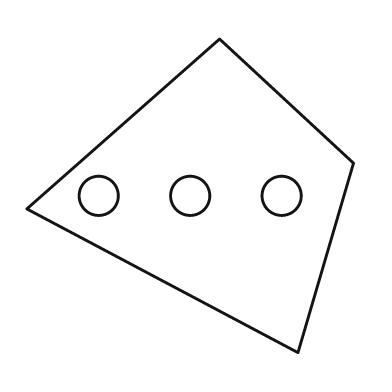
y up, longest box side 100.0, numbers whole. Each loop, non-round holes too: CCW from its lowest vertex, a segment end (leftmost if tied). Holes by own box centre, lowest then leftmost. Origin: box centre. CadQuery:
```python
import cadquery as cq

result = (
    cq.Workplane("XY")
    .moveTo(33.0, -48.0)
    .lineTo(50.0, 10.0)
    .lineTo(9.0, 48.0)
    .lineTo(-50.0, -4.0)
    .close()
    .moveTo(-28.0, 0.0)
    .circle(6.0)
    .moveTo(0.0, 0.0)
    .circle(6.0)
    .moveTo(28.0, 0.0)
    .circle(6.0)
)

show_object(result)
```